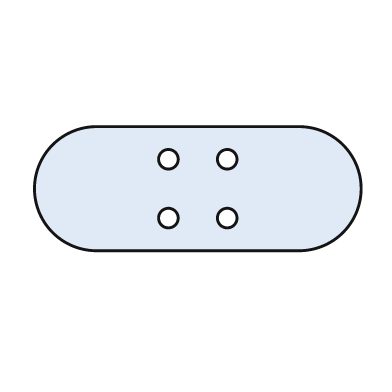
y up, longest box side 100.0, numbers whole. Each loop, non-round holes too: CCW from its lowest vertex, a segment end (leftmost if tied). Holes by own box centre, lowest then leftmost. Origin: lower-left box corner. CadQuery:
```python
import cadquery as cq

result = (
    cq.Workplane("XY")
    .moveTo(19.0, 0.0)
    .lineTo(81.0, 0.0)
    .threePointArc((100.0, 19.0), (81.0, 38.0))
    .lineTo(19.0, 38.0)
    .threePointArc((0.0, 19.0), (19.0, 0.0))
    .close()
    .moveTo(41.0, 10.0)
    .circle(3.0)
    .moveTo(59.0, 10.0)
    .circle(3.0)
    .moveTo(41.0, 28.0)
    .circle(3.0)
    .moveTo(59.0, 28.0)
    .circle(3.0)
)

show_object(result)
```